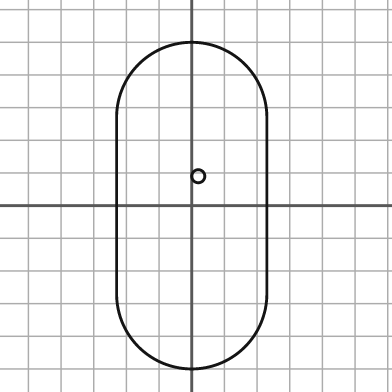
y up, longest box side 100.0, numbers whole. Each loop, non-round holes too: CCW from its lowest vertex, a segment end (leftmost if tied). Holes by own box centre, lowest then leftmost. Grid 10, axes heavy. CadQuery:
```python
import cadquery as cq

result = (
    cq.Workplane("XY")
    .moveTo(-23.0, -27.0)
    .threePointArc((0.0, -50.0), (23.0, -27.0))
    .lineTo(23.0, 27.0)
    .threePointArc((0.0, 50.0), (-23.0, 27.0))
    .close()
    .moveTo(2.0, 9.0)
    .circle(2.0)
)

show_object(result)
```